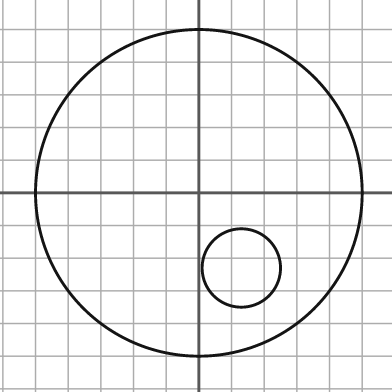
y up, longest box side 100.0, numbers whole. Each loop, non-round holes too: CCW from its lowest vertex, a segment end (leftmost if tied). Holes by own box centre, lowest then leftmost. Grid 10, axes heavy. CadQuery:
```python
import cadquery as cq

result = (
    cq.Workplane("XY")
    .moveTo(0.0, 0.0)
    .circle(50.0)
    .moveTo(13.0, -23.0)
    .circle(12.0)
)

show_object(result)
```